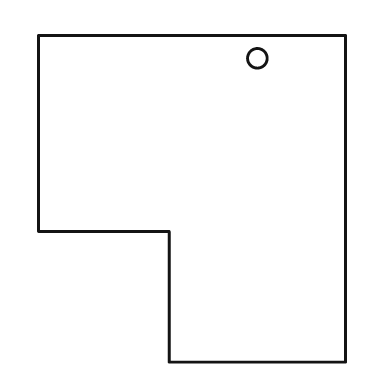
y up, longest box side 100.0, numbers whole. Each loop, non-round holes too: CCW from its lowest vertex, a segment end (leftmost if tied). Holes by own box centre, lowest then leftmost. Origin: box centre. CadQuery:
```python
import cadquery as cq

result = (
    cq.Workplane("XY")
    .moveTo(-7.0, -50.0)
    .lineTo(47.0, -50.0)
    .lineTo(47.0, 50.0)
    .lineTo(-47.0, 50.0)
    .lineTo(-47.0, -10.0)
    .lineTo(-7.0, -10.0)
    .close()
    .moveTo(20.0, 43.0)
    .circle(3.0)
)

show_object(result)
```